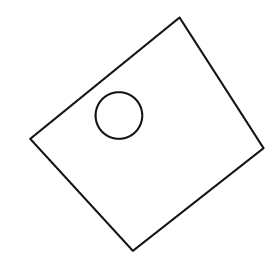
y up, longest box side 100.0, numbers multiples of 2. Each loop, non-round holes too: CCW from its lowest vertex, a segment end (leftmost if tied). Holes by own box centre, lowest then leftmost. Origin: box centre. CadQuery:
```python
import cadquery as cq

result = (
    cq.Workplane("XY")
    .moveTo(-6.0, -50.0)
    .lineTo(50.0, -6.0)
    .lineTo(14.0, 50.0)
    .lineTo(-50.0, -2.0)
    .close()
    .moveTo(-12.0, 8.0)
    .circle(10.0)
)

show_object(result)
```